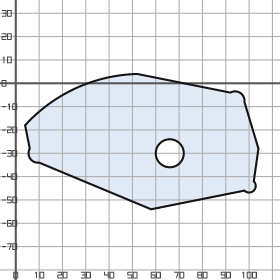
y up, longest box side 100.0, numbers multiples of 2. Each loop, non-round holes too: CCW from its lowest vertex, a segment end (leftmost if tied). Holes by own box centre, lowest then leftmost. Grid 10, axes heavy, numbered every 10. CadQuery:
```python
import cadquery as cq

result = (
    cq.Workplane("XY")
    .moveTo(58.0, -54.0)
    .lineTo(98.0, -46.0)
    .threePointArc((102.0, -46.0), (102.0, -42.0))
    .lineTo(104.0, -28.0)
    .lineTo(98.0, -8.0)
    .threePointArc((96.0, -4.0), (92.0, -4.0))
    .lineTo(52.0, 4.0)
    .threePointArc((26.0, -2.0), (4.0, -18.0))
    .lineTo(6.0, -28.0)
    .threePointArc((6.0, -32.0), (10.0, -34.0))
    .close()
    .moveTo(66.0, -30.0)
    .circle(6.0)
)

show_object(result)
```